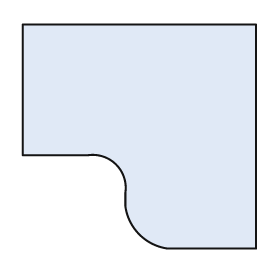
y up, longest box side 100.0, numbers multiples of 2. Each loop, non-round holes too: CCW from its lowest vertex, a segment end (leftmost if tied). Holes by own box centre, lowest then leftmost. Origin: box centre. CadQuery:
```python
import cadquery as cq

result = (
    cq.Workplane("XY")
    .moveTo(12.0, -48.0)
    .lineTo(50.0, -48.0)
    .lineTo(50.0, 48.0)
    .lineTo(-50.0, 48.0)
    .lineTo(-50.0, -8.0)
    .lineTo(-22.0, -8.0)
    .threePointArc((-10.0, -12.0), (-6.0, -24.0))
    .lineTo(-6.0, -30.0)
    .threePointArc((0.0, -42.0), (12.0, -48.0))
    .close()
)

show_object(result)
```